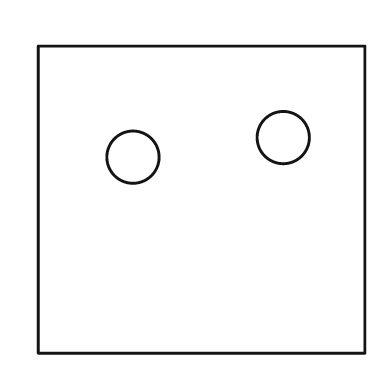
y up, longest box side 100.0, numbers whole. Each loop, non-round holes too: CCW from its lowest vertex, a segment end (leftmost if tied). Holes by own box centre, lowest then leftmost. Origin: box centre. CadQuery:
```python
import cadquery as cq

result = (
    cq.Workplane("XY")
    .moveTo(-50.0, -47.0)
    .lineTo(50.0, -47.0)
    .lineTo(50.0, 47.0)
    .lineTo(-50.0, 47.0)
    .close()
    .moveTo(-21.0, 13.0)
    .circle(8.0)
    .moveTo(25.0, 19.0)
    .circle(8.0)
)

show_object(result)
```